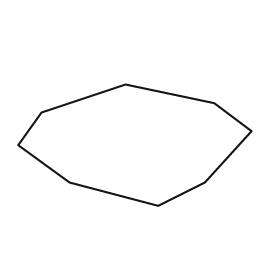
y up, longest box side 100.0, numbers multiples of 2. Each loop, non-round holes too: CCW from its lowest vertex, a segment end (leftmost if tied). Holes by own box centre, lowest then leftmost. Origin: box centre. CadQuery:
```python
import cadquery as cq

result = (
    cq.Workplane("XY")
    .moveTo(10.0, -26.0)
    .lineTo(30.0, -16.0)
    .lineTo(50.0, 6.0)
    .lineTo(34.0, 18.0)
    .lineTo(-4.0, 26.0)
    .lineTo(-40.0, 14.0)
    .lineTo(-50.0, 0.0)
    .lineTo(-28.0, -16.0)
    .close()
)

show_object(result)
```